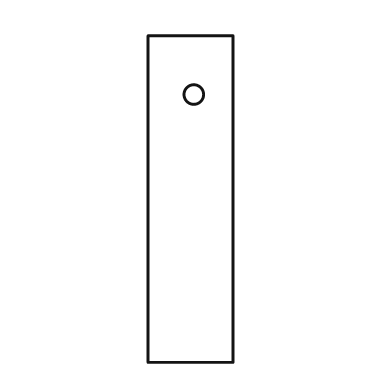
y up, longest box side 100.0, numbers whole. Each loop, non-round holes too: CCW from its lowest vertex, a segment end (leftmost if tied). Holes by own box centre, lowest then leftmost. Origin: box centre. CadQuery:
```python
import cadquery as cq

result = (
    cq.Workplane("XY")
    .moveTo(-13.0, -50.0)
    .lineTo(13.0, -50.0)
    .lineTo(13.0, 50.0)
    .lineTo(-13.0, 50.0)
    .close()
    .moveTo(1.0, 32.0)
    .circle(3.0)
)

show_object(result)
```